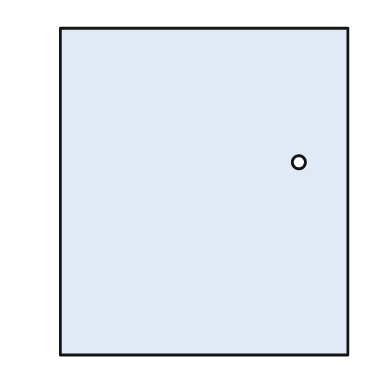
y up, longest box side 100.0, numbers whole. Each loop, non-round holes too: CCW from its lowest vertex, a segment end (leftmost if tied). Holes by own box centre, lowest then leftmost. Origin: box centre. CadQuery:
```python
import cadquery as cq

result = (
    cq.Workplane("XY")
    .moveTo(-44.0, -50.0)
    .lineTo(44.0, -50.0)
    .lineTo(44.0, 50.0)
    .lineTo(-44.0, 50.0)
    .close()
    .moveTo(29.0, 9.0)
    .circle(2.0)
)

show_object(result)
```